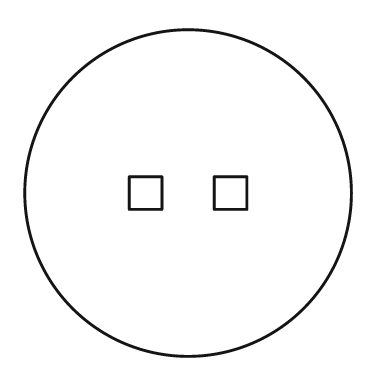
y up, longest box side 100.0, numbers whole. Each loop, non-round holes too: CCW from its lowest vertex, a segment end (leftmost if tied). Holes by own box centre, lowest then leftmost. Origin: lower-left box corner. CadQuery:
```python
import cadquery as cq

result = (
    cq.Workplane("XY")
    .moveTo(50.0, 50.0)
    .circle(50.0)
    .moveTo(32.0, 45.0)
    .lineTo(42.0, 45.0)
    .lineTo(42.0, 55.0)
    .lineTo(32.0, 55.0)
    .close()
    .moveTo(58.0, 45.0)
    .lineTo(68.0, 45.0)
    .lineTo(68.0, 55.0)
    .lineTo(58.0, 55.0)
    .close()
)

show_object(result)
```